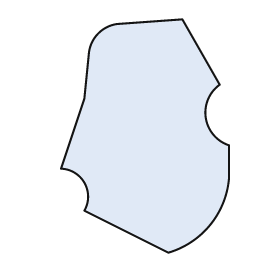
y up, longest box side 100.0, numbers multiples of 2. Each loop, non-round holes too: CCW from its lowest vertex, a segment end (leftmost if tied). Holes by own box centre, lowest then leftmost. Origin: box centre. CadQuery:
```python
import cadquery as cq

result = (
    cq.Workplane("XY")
    .moveTo(10.0, -50.0)
    .threePointArc((28.0, -38.0), (36.0, -18.0))
    .lineTo(36.0, -4.0)
    .threePointArc((26.0, 8.0), (32.0, 22.0))
    .lineTo(16.0, 50.0)
    .lineTo(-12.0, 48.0)
    .threePointArc((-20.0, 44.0), (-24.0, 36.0))
    .lineTo(-26.0, 16.0)
    .lineTo(-36.0, -14.0)
    .threePointArc((-26.0, -20.0), (-26.0, -32.0))
    .close()
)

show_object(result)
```